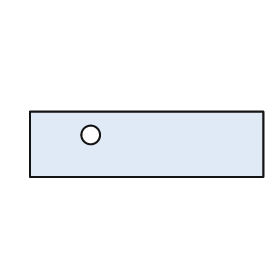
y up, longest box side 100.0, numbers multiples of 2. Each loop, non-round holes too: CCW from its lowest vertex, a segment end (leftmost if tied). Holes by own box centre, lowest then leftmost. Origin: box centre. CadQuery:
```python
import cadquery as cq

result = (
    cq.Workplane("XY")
    .moveTo(-50.0, -14.0)
    .lineTo(50.0, -14.0)
    .lineTo(50.0, 14.0)
    .lineTo(-50.0, 14.0)
    .close()
    .moveTo(-24.0, 4.0)
    .circle(4.0)
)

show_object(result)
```